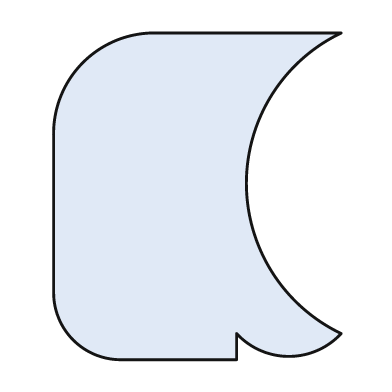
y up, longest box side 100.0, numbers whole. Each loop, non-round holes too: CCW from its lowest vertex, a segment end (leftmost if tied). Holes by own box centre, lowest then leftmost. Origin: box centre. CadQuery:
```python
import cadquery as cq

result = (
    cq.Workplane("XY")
    .moveTo(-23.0, -50.0)
    .lineTo(12.0, -50.0)
    .lineTo(12.0, -42.0)
    .threePointArc((28.0, -49.0), (44.0, -42.0))
    .threePointArc((15.0, 4.0), (44.0, 50.0))
    .lineTo(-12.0, 50.0)
    .threePointArc((-35.0, 41.0), (-44.0, 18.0))
    .lineTo(-44.0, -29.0)
    .threePointArc((-38.0, -44.0), (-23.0, -50.0))
    .close()
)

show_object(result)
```